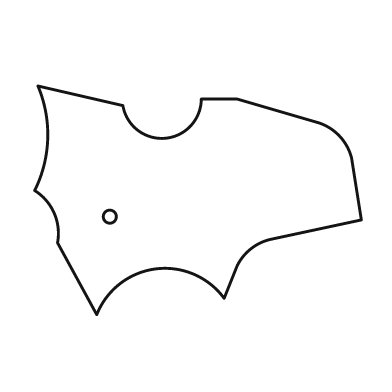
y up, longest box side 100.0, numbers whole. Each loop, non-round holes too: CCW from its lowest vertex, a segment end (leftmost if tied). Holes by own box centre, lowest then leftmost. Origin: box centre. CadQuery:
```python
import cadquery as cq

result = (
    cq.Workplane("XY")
    .moveTo(-31.0, -35.0)
    .threePointArc((-13.0, -21.0), (8.0, -30.0))
    .lineTo(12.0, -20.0)
    .threePointArc((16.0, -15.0), (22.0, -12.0))
    .lineTo(50.0, -6.0)
    .lineTo(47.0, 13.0)
    .threePointArc((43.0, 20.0), (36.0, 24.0))
    .lineTo(12.0, 31.0)
    .lineTo(1.0, 31.0)
    .threePointArc((-10.0, 19.0), (-23.0, 29.0))
    .lineTo(-49.0, 35.0)
    .threePointArc((-46.0, 19.0), (-50.0, 3.0))
    .threePointArc((-44.0, -4.0), (-43.0, -13.0))
    .close()
    .moveTo(-27.0, -5.0)
    .circle(2.0)
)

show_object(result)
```